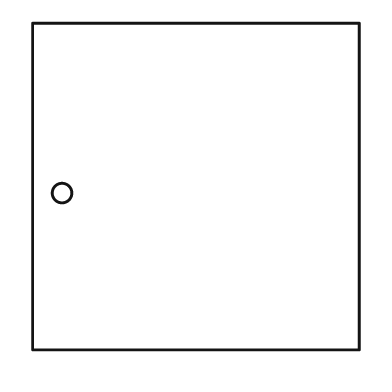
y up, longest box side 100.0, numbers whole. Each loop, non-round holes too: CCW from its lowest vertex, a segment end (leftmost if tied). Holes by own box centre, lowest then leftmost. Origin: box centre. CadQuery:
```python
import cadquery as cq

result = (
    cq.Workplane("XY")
    .moveTo(-50.0, -50.0)
    .lineTo(50.0, -50.0)
    .lineTo(50.0, 50.0)
    .lineTo(-50.0, 50.0)
    .close()
    .moveTo(-41.0, -2.0)
    .circle(3.0)
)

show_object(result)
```